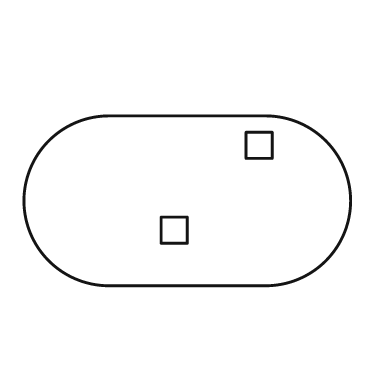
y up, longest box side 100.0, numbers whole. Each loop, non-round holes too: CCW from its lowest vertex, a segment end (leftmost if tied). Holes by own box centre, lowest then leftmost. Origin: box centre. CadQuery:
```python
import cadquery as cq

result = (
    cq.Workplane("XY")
    .moveTo(-24.0, -26.0)
    .lineTo(24.0, -26.0)
    .threePointArc((50.0, 0.0), (24.0, 26.0))
    .lineTo(-24.0, 26.0)
    .threePointArc((-50.0, 0.0), (-24.0, -26.0))
    .close()
    .moveTo(-8.0, -13.0)
    .lineTo(0.0, -13.0)
    .lineTo(0.0, -5.0)
    .lineTo(-8.0, -5.0)
    .close()
    .moveTo(18.0, 13.0)
    .lineTo(26.0, 13.0)
    .lineTo(26.0, 21.0)
    .lineTo(18.0, 21.0)
    .close()
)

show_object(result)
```